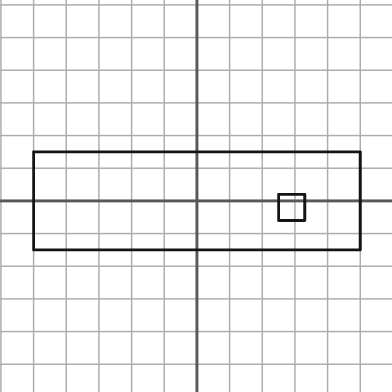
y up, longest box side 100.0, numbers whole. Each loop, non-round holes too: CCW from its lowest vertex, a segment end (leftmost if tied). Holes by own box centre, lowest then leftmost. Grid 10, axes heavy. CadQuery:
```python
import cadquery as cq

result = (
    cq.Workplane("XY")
    .moveTo(-50.0, -15.0)
    .lineTo(50.0, -15.0)
    .lineTo(50.0, 15.0)
    .lineTo(-50.0, 15.0)
    .close()
    .moveTo(25.0, -6.0)
    .lineTo(33.0, -6.0)
    .lineTo(33.0, 2.0)
    .lineTo(25.0, 2.0)
    .close()
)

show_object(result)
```